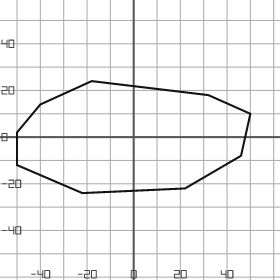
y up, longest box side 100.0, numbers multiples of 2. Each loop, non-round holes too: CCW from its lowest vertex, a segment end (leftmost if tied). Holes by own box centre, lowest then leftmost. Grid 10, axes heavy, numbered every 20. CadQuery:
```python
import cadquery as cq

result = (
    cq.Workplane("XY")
    .moveTo(-22.0, -24.0)
    .lineTo(22.0, -22.0)
    .lineTo(46.0, -8.0)
    .lineTo(50.0, 10.0)
    .lineTo(32.0, 18.0)
    .lineTo(-18.0, 24.0)
    .lineTo(-40.0, 14.0)
    .lineTo(-50.0, 2.0)
    .lineTo(-50.0, -12.0)
    .close()
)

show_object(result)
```